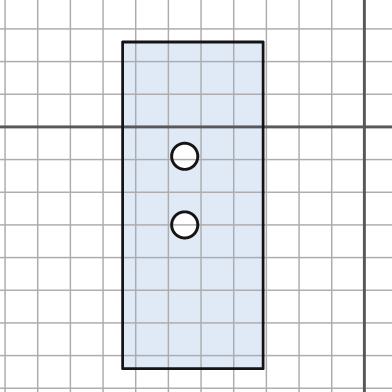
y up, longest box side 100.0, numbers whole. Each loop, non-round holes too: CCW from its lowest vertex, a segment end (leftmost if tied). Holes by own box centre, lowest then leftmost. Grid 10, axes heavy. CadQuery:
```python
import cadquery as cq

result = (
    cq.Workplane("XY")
    .moveTo(-74.0, -74.0)
    .lineTo(-31.0, -74.0)
    .lineTo(-31.0, 26.0)
    .lineTo(-74.0, 26.0)
    .close()
    .moveTo(-55.0, -30.0)
    .circle(4.0)
    .moveTo(-55.0, -9.0)
    .circle(4.0)
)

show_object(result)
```